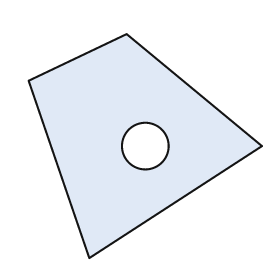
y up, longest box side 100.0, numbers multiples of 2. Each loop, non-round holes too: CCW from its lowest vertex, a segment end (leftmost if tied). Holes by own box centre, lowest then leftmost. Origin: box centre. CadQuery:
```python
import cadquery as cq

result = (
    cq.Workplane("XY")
    .moveTo(-24.0, -48.0)
    .lineTo(50.0, 0.0)
    .lineTo(-8.0, 48.0)
    .lineTo(-50.0, 28.0)
    .close()
    .moveTo(0.0, 0.0)
    .circle(10.0)
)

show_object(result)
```